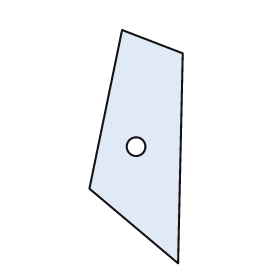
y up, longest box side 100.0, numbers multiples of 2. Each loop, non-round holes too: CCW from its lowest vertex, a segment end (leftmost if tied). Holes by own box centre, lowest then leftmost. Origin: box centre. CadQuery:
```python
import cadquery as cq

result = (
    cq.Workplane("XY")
    .moveTo(18.0, -50.0)
    .lineTo(20.0, 40.0)
    .lineTo(-6.0, 50.0)
    .lineTo(-20.0, -18.0)
    .close()
    .moveTo(0.0, 0.0)
    .circle(4.0)
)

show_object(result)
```